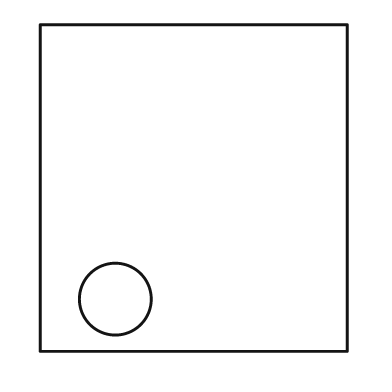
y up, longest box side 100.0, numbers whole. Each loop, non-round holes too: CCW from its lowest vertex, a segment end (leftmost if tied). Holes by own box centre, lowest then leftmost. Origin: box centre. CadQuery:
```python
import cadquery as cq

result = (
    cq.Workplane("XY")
    .moveTo(-47.0, -50.0)
    .lineTo(47.0, -50.0)
    .lineTo(47.0, 50.0)
    .lineTo(-47.0, 50.0)
    .close()
    .moveTo(-24.0, -34.0)
    .circle(11.0)
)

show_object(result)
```